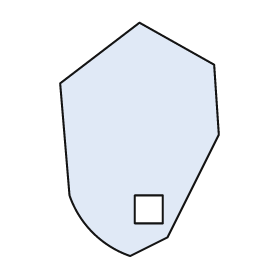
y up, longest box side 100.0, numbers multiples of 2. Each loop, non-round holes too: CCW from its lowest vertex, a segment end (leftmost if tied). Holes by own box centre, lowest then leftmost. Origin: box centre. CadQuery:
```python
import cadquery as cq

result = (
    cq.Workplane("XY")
    .moveTo(-4.0, -50.0)
    .lineTo(12.0, -42.0)
    .lineTo(34.0, 2.0)
    .lineTo(32.0, 32.0)
    .lineTo(0.0, 50.0)
    .lineTo(-34.0, 24.0)
    .lineTo(-30.0, -24.0)
    .threePointArc((-20.0, -40.0), (-4.0, -50.0))
    .close()
    .moveTo(-2.0, -36.0)
    .lineTo(10.0, -36.0)
    .lineTo(10.0, -24.0)
    .lineTo(-2.0, -24.0)
    .close()
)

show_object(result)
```